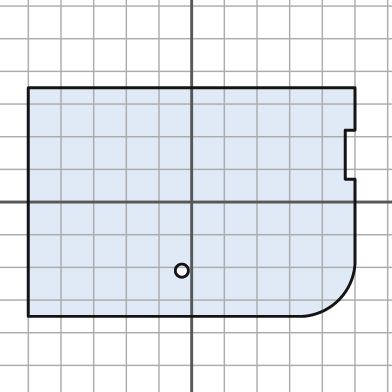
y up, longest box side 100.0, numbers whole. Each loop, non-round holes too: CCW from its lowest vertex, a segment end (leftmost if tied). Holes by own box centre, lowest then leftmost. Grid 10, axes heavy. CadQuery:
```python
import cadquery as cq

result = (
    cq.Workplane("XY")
    .moveTo(-50.0, -35.0)
    .lineTo(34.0, -35.0)
    .threePointArc((45.0, -30.0), (50.0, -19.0))
    .lineTo(50.0, 7.0)
    .lineTo(47.0, 7.0)
    .lineTo(47.0, 22.0)
    .lineTo(50.0, 22.0)
    .lineTo(50.0, 35.0)
    .lineTo(-50.0, 35.0)
    .close()
    .moveTo(-3.0, -21.0)
    .circle(2.0)
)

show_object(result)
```